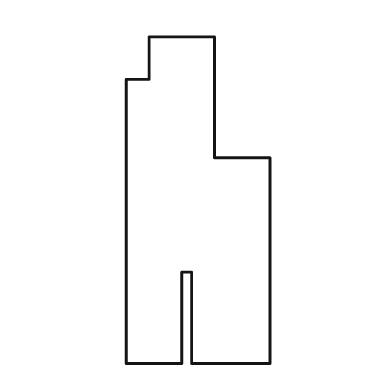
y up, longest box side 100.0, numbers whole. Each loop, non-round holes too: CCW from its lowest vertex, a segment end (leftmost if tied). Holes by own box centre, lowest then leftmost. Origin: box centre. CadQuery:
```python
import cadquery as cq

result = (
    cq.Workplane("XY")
    .moveTo(-22.0, -50.0)
    .lineTo(-5.0, -50.0)
    .lineTo(-5.0, -22.0)
    .lineTo(-2.0, -22.0)
    .lineTo(-2.0, -50.0)
    .lineTo(22.0, -50.0)
    .lineTo(22.0, 13.0)
    .lineTo(5.0, 13.0)
    .lineTo(5.0, 50.0)
    .lineTo(-15.0, 50.0)
    .lineTo(-15.0, 37.0)
    .lineTo(-22.0, 37.0)
    .close()
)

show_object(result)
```